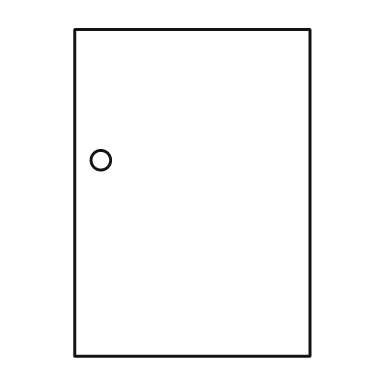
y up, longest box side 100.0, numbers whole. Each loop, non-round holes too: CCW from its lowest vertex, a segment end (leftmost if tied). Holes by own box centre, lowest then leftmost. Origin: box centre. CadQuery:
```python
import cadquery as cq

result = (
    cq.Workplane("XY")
    .moveTo(-36.0, -50.0)
    .lineTo(36.0, -50.0)
    .lineTo(36.0, 50.0)
    .lineTo(-36.0, 50.0)
    .close()
    .moveTo(-28.0, 10.0)
    .circle(3.0)
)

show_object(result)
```